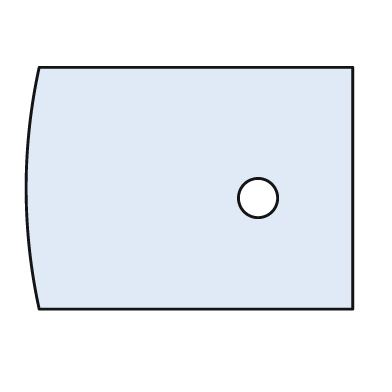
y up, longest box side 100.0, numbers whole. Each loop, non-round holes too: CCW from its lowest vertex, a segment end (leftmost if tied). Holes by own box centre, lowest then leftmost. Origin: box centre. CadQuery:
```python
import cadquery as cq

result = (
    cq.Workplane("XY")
    .moveTo(-46.0, -37.0)
    .lineTo(50.0, -37.0)
    .lineTo(50.0, 37.0)
    .lineTo(-46.0, 37.0)
    .threePointArc((-50.0, 0.0), (-46.0, -37.0))
    .close()
    .moveTo(21.0, -3.0)
    .circle(6.0)
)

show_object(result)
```